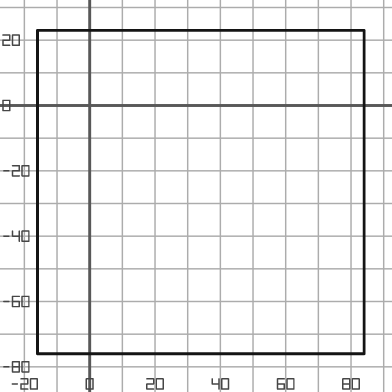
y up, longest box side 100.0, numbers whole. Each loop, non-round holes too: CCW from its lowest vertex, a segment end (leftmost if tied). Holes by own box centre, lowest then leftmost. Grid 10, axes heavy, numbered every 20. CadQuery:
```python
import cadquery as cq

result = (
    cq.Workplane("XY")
    .moveTo(-16.0, -76.0)
    .lineTo(84.0, -76.0)
    .lineTo(84.0, 23.0)
    .lineTo(-16.0, 23.0)
    .close()
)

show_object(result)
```